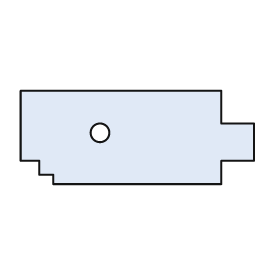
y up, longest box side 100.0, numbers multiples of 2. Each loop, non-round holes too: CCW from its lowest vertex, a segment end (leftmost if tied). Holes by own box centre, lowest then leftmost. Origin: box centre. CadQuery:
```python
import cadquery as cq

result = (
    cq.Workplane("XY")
    .moveTo(-36.0, -20.0)
    .lineTo(36.0, -20.0)
    .lineTo(36.0, -10.0)
    .lineTo(50.0, -10.0)
    .lineTo(50.0, 6.0)
    .lineTo(36.0, 6.0)
    .lineTo(36.0, 20.0)
    .lineTo(-50.0, 20.0)
    .lineTo(-50.0, -10.0)
    .lineTo(-42.0, -10.0)
    .lineTo(-42.0, -16.0)
    .lineTo(-36.0, -16.0)
    .close()
    .moveTo(-16.0, 2.0)
    .circle(4.0)
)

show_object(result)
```